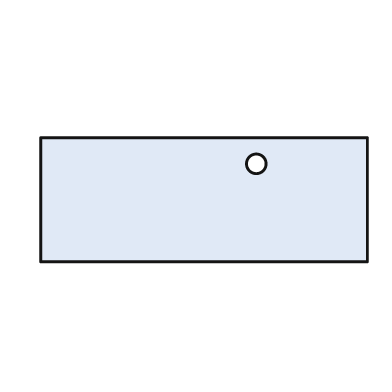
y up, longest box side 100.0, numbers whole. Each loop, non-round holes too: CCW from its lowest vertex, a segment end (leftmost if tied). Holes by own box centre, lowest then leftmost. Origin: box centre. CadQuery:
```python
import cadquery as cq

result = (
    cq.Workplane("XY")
    .moveTo(-50.0, -19.0)
    .lineTo(50.0, -19.0)
    .lineTo(50.0, 19.0)
    .lineTo(-50.0, 19.0)
    .close()
    .moveTo(16.0, 11.0)
    .circle(3.0)
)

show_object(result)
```